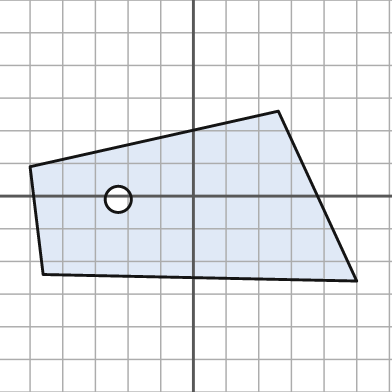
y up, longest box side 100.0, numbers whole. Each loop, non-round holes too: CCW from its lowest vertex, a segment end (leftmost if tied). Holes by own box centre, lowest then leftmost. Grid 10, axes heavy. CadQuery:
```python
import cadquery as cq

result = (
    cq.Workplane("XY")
    .moveTo(50.0, -26.0)
    .lineTo(26.0, 26.0)
    .lineTo(-50.0, 9.0)
    .lineTo(-46.0, -24.0)
    .close()
    .moveTo(-23.0, -1.0)
    .circle(4.0)
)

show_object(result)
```